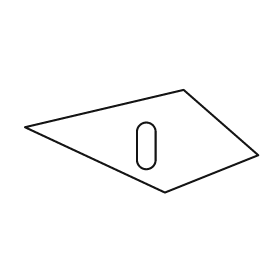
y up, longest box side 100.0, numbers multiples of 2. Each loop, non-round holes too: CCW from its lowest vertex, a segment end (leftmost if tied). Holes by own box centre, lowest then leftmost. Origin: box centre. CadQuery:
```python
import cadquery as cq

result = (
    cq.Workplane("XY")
    .moveTo(10.0, -22.0)
    .lineTo(50.0, -6.0)
    .lineTo(18.0, 22.0)
    .lineTo(-50.0, 6.0)
    .close()
    .moveTo(-2.0, -8.0)
    .threePointArc((2.0, -12.0), (6.0, -8.0))
    .lineTo(6.0, 4.0)
    .threePointArc((2.0, 8.0), (-2.0, 4.0))
    .close()
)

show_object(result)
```